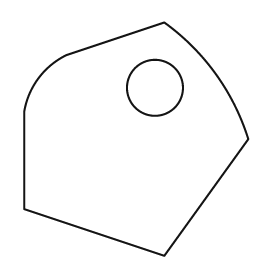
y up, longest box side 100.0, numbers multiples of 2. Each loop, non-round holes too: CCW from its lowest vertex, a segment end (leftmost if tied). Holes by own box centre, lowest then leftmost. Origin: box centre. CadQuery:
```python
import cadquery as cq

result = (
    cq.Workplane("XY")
    .moveTo(12.0, -50.0)
    .lineTo(48.0, 0.0)
    .threePointArc((34.0, 28.0), (12.0, 50.0))
    .lineTo(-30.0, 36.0)
    .threePointArc((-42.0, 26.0), (-48.0, 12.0))
    .lineTo(-48.0, -30.0)
    .close()
    .moveTo(8.0, 22.0)
    .circle(12.0)
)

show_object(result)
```